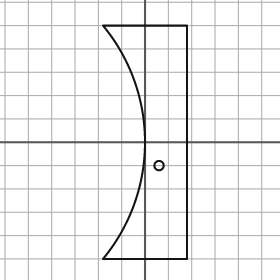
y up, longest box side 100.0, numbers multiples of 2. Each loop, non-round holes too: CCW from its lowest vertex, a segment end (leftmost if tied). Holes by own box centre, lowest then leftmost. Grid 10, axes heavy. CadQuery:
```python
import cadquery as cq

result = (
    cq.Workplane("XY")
    .moveTo(-18.0, -50.0)
    .lineTo(18.0, -50.0)
    .lineTo(18.0, 50.0)
    .lineTo(-18.0, 50.0)
    .threePointArc((0.0, 0.0), (-18.0, -50.0))
    .close()
    .moveTo(6.0, -10.0)
    .circle(2.0)
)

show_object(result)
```